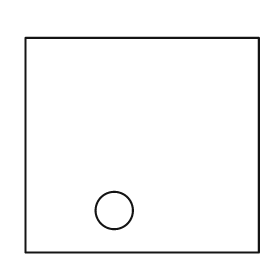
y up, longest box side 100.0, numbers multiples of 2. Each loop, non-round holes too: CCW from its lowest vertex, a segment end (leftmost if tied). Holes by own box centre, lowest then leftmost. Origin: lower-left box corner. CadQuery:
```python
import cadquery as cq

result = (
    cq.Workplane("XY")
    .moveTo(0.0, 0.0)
    .lineTo(100.0, 0.0)
    .lineTo(100.0, 92.0)
    .lineTo(0.0, 92.0)
    .close()
    .moveTo(38.0, 18.0)
    .circle(8.0)
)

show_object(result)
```